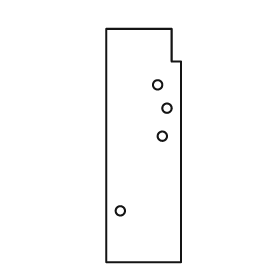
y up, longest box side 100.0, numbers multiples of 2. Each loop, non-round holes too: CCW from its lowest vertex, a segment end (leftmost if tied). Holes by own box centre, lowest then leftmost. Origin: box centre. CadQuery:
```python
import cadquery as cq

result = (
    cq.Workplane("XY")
    .moveTo(-16.0, -50.0)
    .lineTo(16.0, -50.0)
    .lineTo(16.0, 36.0)
    .lineTo(12.0, 36.0)
    .lineTo(12.0, 50.0)
    .lineTo(-16.0, 50.0)
    .close()
    .moveTo(-10.0, -28.0)
    .circle(2.0)
    .moveTo(8.0, 4.0)
    .circle(2.0)
    .moveTo(10.0, 16.0)
    .circle(2.0)
    .moveTo(6.0, 26.0)
    .circle(2.0)
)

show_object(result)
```